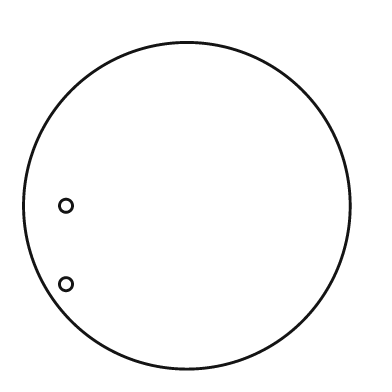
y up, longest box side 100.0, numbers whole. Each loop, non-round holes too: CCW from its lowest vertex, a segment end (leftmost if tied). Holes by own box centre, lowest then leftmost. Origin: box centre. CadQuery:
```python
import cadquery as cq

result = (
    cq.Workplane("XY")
    .moveTo(0.0, 0.0)
    .circle(50.0)
    .moveTo(-37.0, -24.0)
    .circle(2.0)
    .moveTo(-37.0, 0.0)
    .circle(2.0)
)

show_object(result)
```